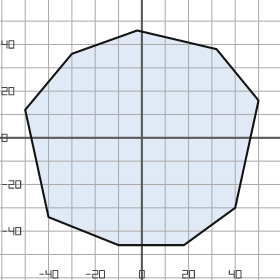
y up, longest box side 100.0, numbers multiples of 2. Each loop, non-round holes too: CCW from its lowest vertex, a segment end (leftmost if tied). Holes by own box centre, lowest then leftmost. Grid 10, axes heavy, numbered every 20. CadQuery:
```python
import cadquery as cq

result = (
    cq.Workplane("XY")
    .moveTo(-10.0, -46.0)
    .lineTo(18.0, -46.0)
    .lineTo(40.0, -30.0)
    .lineTo(50.0, 16.0)
    .lineTo(32.0, 38.0)
    .lineTo(-2.0, 46.0)
    .lineTo(-30.0, 36.0)
    .lineTo(-50.0, 12.0)
    .lineTo(-40.0, -34.0)
    .close()
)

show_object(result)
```